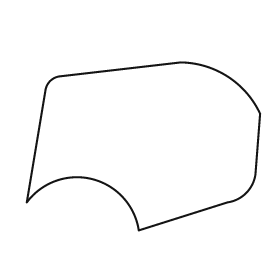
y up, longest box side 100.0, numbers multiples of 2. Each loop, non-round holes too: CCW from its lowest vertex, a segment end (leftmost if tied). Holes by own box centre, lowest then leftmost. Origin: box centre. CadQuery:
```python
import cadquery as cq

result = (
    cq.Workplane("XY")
    .moveTo(-2.0, -36.0)
    .lineTo(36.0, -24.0)
    .threePointArc((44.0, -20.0), (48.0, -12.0))
    .lineTo(50.0, 14.0)
    .threePointArc((36.0, 30.0), (16.0, 36.0))
    .lineTo(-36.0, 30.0)
    .threePointArc((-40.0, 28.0), (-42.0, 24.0))
    .lineTo(-50.0, -24.0)
    .threePointArc((-22.0, -14.0), (-2.0, -36.0))
    .close()
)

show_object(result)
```